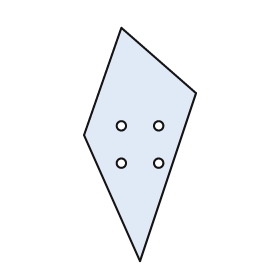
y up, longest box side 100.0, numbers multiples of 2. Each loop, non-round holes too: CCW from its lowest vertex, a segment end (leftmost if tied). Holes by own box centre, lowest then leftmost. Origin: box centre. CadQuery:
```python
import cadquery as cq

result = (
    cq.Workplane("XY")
    .moveTo(0.0, -50.0)
    .lineTo(24.0, 22.0)
    .lineTo(-8.0, 50.0)
    .lineTo(-24.0, 4.0)
    .close()
    .moveTo(-8.0, -8.0)
    .circle(2.0)
    .moveTo(8.0, -8.0)
    .circle(2.0)
    .moveTo(-8.0, 8.0)
    .circle(2.0)
    .moveTo(8.0, 8.0)
    .circle(2.0)
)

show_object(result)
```